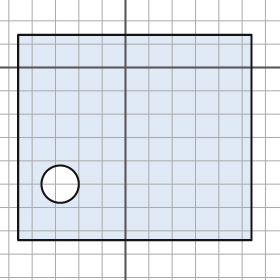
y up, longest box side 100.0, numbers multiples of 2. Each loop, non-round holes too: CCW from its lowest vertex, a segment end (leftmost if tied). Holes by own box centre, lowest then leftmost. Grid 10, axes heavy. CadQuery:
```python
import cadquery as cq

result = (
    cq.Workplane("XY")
    .moveTo(-46.0, -74.0)
    .lineTo(54.0, -74.0)
    .lineTo(54.0, 14.0)
    .lineTo(-46.0, 14.0)
    .close()
    .moveTo(-28.0, -50.0)
    .circle(8.0)
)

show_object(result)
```